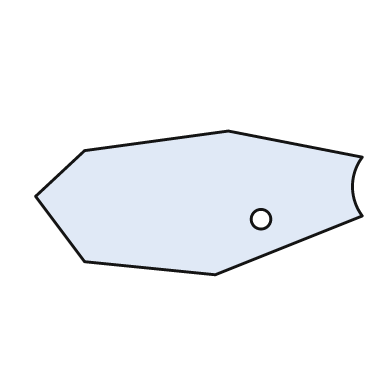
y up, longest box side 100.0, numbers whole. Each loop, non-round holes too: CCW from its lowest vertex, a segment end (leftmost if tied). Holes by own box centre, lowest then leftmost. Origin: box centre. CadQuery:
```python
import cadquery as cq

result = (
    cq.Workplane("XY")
    .moveTo(5.0, -22.0)
    .lineTo(50.0, -4.0)
    .threePointArc((47.0, 5.0), (50.0, 14.0))
    .lineTo(9.0, 22.0)
    .lineTo(-35.0, 16.0)
    .lineTo(-50.0, 2.0)
    .lineTo(-35.0, -18.0)
    .close()
    .moveTo(19.0, -5.0)
    .circle(3.0)
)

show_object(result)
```